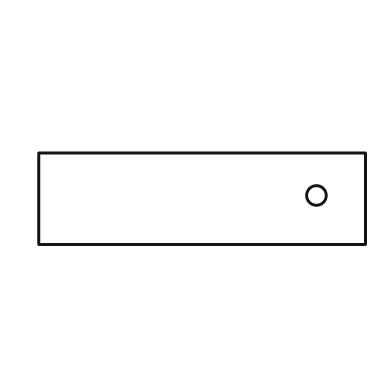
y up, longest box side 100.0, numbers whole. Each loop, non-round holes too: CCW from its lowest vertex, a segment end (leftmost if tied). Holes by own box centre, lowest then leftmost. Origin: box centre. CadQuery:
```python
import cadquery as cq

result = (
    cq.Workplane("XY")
    .moveTo(-50.0, -14.0)
    .lineTo(50.0, -14.0)
    .lineTo(50.0, 14.0)
    .lineTo(-50.0, 14.0)
    .close()
    .moveTo(35.0, 1.0)
    .circle(3.0)
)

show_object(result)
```